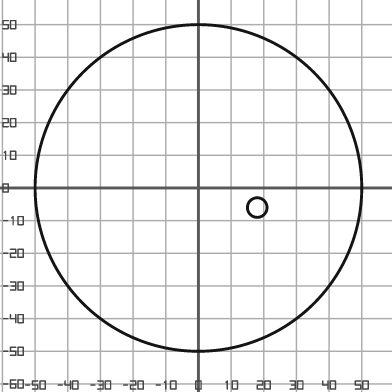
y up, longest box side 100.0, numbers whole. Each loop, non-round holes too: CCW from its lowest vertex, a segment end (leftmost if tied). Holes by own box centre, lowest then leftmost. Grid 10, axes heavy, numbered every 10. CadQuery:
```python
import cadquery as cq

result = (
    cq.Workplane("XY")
    .moveTo(0.0, 0.0)
    .circle(50.0)
    .moveTo(18.0, -6.0)
    .circle(3.0)
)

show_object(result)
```